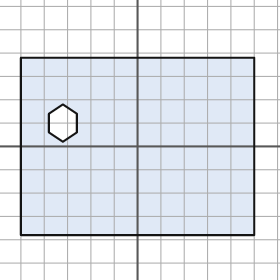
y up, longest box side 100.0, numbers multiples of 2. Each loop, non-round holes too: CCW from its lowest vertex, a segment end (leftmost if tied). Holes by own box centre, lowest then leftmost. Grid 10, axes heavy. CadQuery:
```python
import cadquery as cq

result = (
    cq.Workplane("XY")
    .moveTo(-50.0, -38.0)
    .lineTo(50.0, -38.0)
    .lineTo(50.0, 38.0)
    .lineTo(-50.0, 38.0)
    .close()
    .moveTo(-32.0, 2.0)
    .lineTo(-26.0, 6.0)
    .lineTo(-26.0, 14.0)
    .lineTo(-32.0, 18.0)
    .lineTo(-38.0, 14.0)
    .lineTo(-38.0, 6.0)
    .close()
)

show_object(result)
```